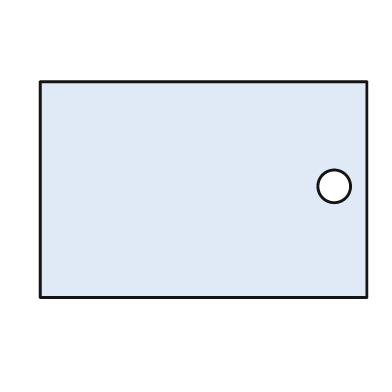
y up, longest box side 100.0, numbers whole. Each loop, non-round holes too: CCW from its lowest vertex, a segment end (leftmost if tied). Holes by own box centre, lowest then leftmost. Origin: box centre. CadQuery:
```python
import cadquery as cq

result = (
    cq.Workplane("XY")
    .moveTo(-50.0, -33.0)
    .lineTo(50.0, -33.0)
    .lineTo(50.0, 33.0)
    .lineTo(-50.0, 33.0)
    .close()
    .moveTo(40.0, 1.0)
    .circle(5.0)
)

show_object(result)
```